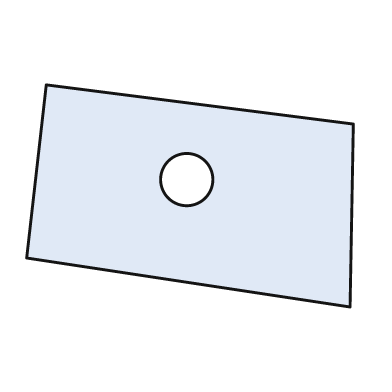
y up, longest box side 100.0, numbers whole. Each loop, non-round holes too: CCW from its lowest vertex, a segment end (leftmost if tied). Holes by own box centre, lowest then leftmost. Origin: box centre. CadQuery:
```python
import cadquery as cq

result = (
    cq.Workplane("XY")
    .moveTo(49.0, -34.0)
    .lineTo(50.0, 22.0)
    .lineTo(-44.0, 34.0)
    .lineTo(-50.0, -19.0)
    .close()
    .moveTo(-1.0, 5.0)
    .circle(8.0)
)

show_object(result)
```